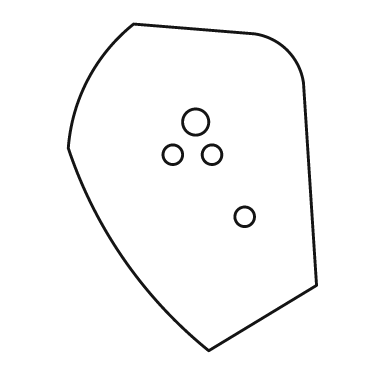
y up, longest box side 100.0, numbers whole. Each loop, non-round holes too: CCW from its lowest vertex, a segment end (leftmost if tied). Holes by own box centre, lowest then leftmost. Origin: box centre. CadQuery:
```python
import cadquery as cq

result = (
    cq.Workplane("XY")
    .moveTo(5.0, -50.0)
    .lineTo(38.0, -30.0)
    .lineTo(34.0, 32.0)
    .threePointArc((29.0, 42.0), (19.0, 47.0))
    .lineTo(-18.0, 50.0)
    .threePointArc((-32.0, 33.0), (-38.0, 12.0))
    .threePointArc((-21.0, -22.0), (5.0, -50.0))
    .close()
    .moveTo(16.0, -9.0)
    .circle(3.0)
    .moveTo(-6.0, 10.0)
    .circle(3.0)
    .moveTo(6.0, 10.0)
    .circle(3.0)
    .moveTo(1.0, 20.0)
    .circle(4.0)
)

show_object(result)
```